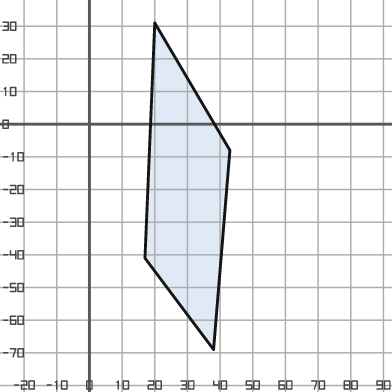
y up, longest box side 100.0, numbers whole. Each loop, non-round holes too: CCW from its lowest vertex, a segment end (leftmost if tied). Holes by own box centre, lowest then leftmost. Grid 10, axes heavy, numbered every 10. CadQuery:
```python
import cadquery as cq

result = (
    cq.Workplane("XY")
    .moveTo(38.0, -69.0)
    .lineTo(43.0, -8.0)
    .lineTo(20.0, 31.0)
    .lineTo(17.0, -41.0)
    .close()
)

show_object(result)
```